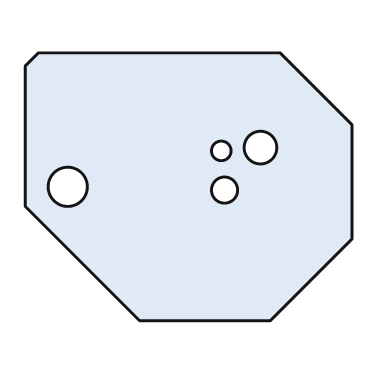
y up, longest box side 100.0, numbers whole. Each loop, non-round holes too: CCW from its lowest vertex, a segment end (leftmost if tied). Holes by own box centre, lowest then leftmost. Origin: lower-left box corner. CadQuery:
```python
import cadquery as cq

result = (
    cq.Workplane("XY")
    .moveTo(35.0, 0.0)
    .lineTo(75.0, 0.0)
    .lineTo(100.0, 25.0)
    .lineTo(100.0, 60.0)
    .lineTo(78.0, 82.0)
    .lineTo(4.0, 82.0)
    .lineTo(0.0, 78.0)
    .lineTo(0.0, 35.0)
    .close()
    .moveTo(61.0, 40.0)
    .circle(4.0)
    .moveTo(13.0, 41.0)
    .circle(6.0)
    .moveTo(60.0, 52.0)
    .circle(3.0)
    .moveTo(72.0, 53.0)
    .circle(5.0)
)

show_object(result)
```